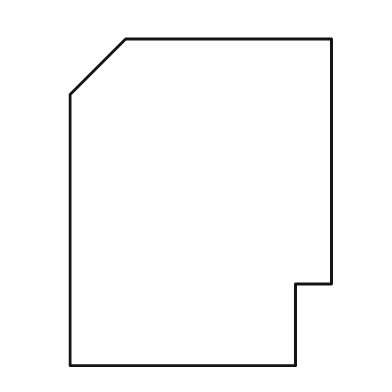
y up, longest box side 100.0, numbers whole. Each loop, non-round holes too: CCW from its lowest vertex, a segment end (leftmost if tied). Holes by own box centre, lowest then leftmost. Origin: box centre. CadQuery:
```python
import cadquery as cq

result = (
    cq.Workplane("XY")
    .moveTo(-40.0, -50.0)
    .lineTo(29.0, -50.0)
    .lineTo(29.0, -25.0)
    .lineTo(40.0, -25.0)
    .lineTo(40.0, 50.0)
    .lineTo(-23.0, 50.0)
    .lineTo(-40.0, 33.0)
    .close()
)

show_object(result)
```